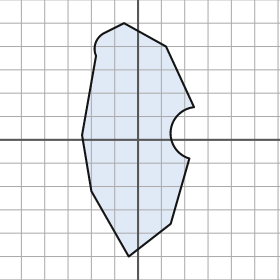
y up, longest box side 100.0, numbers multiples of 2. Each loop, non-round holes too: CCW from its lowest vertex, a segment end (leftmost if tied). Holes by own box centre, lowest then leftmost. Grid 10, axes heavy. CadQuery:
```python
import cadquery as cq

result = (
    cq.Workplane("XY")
    .moveTo(-4.0, -50.0)
    .lineTo(14.0, -36.0)
    .lineTo(22.0, -8.0)
    .threePointArc((14.0, 4.0), (24.0, 14.0))
    .lineTo(12.0, 40.0)
    .lineTo(-6.0, 50.0)
    .lineTo(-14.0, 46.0)
    .threePointArc((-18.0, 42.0), (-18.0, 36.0))
    .lineTo(-24.0, 2.0)
    .lineTo(-20.0, -22.0)
    .close()
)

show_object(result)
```